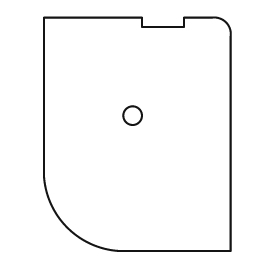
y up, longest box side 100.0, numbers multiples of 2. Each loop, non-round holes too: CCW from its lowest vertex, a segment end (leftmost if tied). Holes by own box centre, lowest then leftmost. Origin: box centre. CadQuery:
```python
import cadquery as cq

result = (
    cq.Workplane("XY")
    .moveTo(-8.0, -50.0)
    .lineTo(40.0, -50.0)
    .lineTo(40.0, 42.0)
    .threePointArc((38.0, 48.0), (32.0, 50.0))
    .lineTo(20.0, 50.0)
    .lineTo(20.0, 46.0)
    .lineTo(2.0, 46.0)
    .lineTo(2.0, 50.0)
    .lineTo(-40.0, 50.0)
    .lineTo(-40.0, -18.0)
    .threePointArc((-30.0, -40.0), (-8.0, -50.0))
    .close()
    .moveTo(-2.0, 8.0)
    .circle(4.0)
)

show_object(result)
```